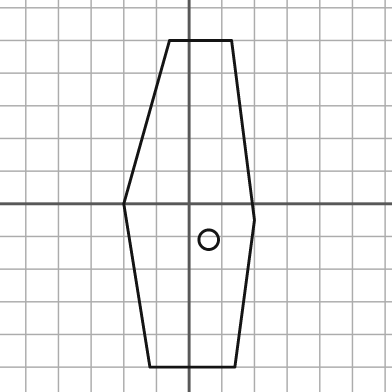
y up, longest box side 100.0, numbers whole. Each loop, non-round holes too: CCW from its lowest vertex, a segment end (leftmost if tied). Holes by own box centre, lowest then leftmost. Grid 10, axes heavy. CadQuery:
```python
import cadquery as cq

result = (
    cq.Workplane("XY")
    .moveTo(-12.0, -50.0)
    .lineTo(14.0, -50.0)
    .lineTo(20.0, -5.0)
    .lineTo(13.0, 50.0)
    .lineTo(-6.0, 50.0)
    .lineTo(-20.0, 0.0)
    .close()
    .moveTo(6.0, -11.0)
    .circle(3.0)
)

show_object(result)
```